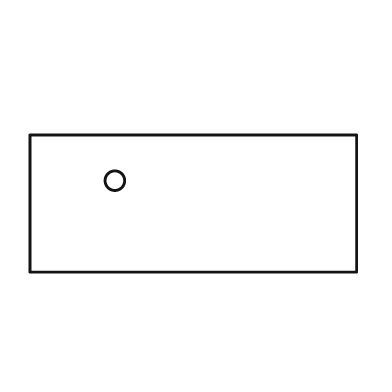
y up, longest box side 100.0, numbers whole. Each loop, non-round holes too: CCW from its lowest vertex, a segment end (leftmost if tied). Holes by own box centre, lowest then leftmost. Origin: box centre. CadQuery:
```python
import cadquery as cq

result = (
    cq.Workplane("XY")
    .moveTo(-50.0, -21.0)
    .lineTo(50.0, -21.0)
    .lineTo(50.0, 21.0)
    .lineTo(-50.0, 21.0)
    .close()
    .moveTo(-24.0, 7.0)
    .circle(3.0)
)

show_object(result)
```